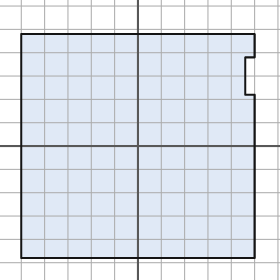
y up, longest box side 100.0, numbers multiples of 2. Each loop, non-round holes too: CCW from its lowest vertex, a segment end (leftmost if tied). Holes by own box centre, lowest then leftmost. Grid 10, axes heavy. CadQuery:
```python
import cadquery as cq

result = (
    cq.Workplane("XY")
    .moveTo(-50.0, -48.0)
    .lineTo(50.0, -48.0)
    .lineTo(50.0, 22.0)
    .lineTo(46.0, 22.0)
    .lineTo(46.0, 38.0)
    .lineTo(50.0, 38.0)
    .lineTo(50.0, 48.0)
    .lineTo(-50.0, 48.0)
    .close()
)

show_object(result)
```